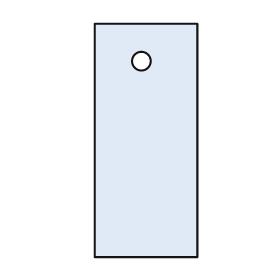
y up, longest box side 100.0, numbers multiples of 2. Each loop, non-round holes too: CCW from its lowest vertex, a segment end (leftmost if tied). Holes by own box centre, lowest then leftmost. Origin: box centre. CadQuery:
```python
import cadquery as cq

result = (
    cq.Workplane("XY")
    .moveTo(-22.0, -50.0)
    .lineTo(22.0, -50.0)
    .lineTo(22.0, 50.0)
    .lineTo(-22.0, 50.0)
    .close()
    .moveTo(-2.0, 34.0)
    .circle(4.0)
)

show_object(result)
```